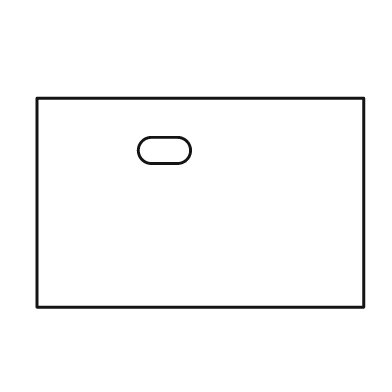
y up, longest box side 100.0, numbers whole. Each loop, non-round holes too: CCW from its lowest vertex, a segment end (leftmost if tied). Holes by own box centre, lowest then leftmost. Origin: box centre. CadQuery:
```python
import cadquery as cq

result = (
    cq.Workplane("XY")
    .moveTo(-50.0, -32.0)
    .lineTo(50.0, -32.0)
    .lineTo(50.0, 32.0)
    .lineTo(-50.0, 32.0)
    .close()
    .moveTo(-15.0, 12.0)
    .lineTo(-7.0, 12.0)
    .threePointArc((-3.0, 16.0), (-7.0, 20.0))
    .lineTo(-15.0, 20.0)
    .threePointArc((-19.0, 16.0), (-15.0, 12.0))
    .close()
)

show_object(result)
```